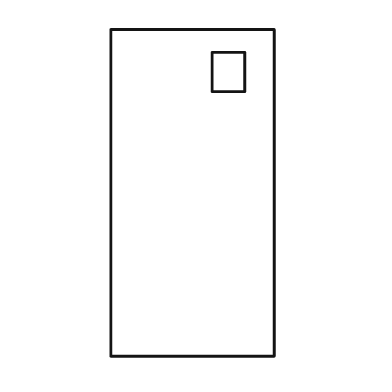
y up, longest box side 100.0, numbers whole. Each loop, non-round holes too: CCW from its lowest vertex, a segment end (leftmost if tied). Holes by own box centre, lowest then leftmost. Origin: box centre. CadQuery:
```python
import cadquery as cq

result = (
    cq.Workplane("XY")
    .moveTo(-25.0, -50.0)
    .lineTo(25.0, -50.0)
    .lineTo(25.0, 50.0)
    .lineTo(-25.0, 50.0)
    .close()
    .moveTo(6.0, 31.0)
    .lineTo(16.0, 31.0)
    .lineTo(16.0, 43.0)
    .lineTo(6.0, 43.0)
    .close()
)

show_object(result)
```